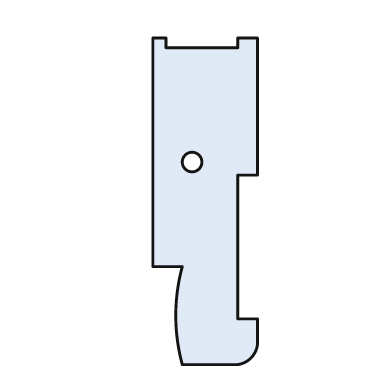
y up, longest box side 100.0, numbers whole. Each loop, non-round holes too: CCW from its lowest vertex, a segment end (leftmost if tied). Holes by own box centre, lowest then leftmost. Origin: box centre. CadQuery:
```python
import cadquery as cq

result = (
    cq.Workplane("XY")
    .moveTo(-7.0, -50.0)
    .lineTo(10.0, -50.0)
    .threePointArc((14.0, -48.0), (16.0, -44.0))
    .lineTo(16.0, -36.0)
    .lineTo(10.0, -36.0)
    .lineTo(10.0, 8.0)
    .lineTo(16.0, 8.0)
    .lineTo(16.0, 50.0)
    .lineTo(10.0, 50.0)
    .lineTo(10.0, 47.0)
    .lineTo(-12.0, 47.0)
    .lineTo(-12.0, 50.0)
    .lineTo(-16.0, 50.0)
    .lineTo(-16.0, -20.0)
    .lineTo(-7.0, -20.0)
    .threePointArc((-9.0, -35.0), (-7.0, -50.0))
    .close()
    .moveTo(-4.0, 12.0)
    .circle(3.0)
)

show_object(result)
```